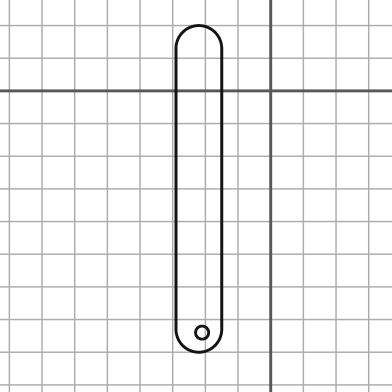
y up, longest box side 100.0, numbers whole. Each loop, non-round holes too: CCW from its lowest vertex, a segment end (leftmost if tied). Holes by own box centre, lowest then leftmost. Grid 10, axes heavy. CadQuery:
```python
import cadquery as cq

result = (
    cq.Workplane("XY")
    .moveTo(-29.0, -73.0)
    .threePointArc((-22.0, -80.0), (-15.0, -73.0))
    .lineTo(-15.0, 13.0)
    .threePointArc((-22.0, 20.0), (-29.0, 13.0))
    .close()
    .moveTo(-21.0, -74.0)
    .circle(2.0)
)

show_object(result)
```